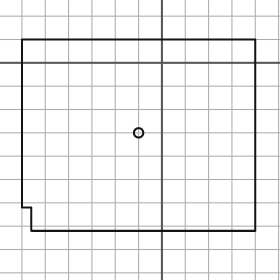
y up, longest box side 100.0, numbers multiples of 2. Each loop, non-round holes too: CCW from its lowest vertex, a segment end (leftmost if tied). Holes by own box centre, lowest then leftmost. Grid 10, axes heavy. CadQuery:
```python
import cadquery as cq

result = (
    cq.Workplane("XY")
    .moveTo(-56.0, -72.0)
    .lineTo(40.0, -72.0)
    .lineTo(40.0, 10.0)
    .lineTo(-60.0, 10.0)
    .lineTo(-60.0, -62.0)
    .lineTo(-56.0, -62.0)
    .close()
    .moveTo(-10.0, -30.0)
    .circle(2.0)
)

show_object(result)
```